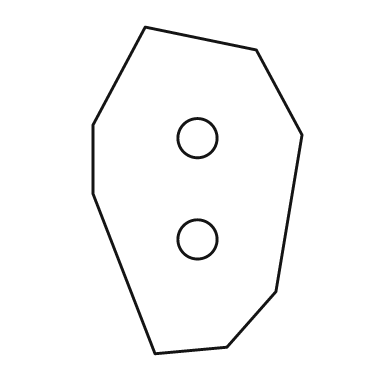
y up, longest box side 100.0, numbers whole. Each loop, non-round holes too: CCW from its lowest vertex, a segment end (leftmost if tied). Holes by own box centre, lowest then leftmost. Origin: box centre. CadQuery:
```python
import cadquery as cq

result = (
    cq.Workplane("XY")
    .moveTo(-13.0, -50.0)
    .lineTo(9.0, -48.0)
    .lineTo(24.0, -31.0)
    .lineTo(32.0, 17.0)
    .lineTo(18.0, 43.0)
    .lineTo(-16.0, 50.0)
    .lineTo(-32.0, 20.0)
    .lineTo(-32.0, -1.0)
    .close()
    .moveTo(0.0, -15.0)
    .circle(6.0)
    .moveTo(0.0, 16.0)
    .circle(6.0)
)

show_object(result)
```